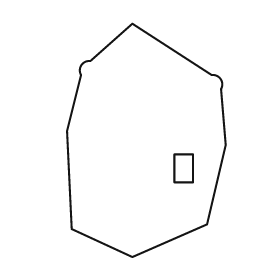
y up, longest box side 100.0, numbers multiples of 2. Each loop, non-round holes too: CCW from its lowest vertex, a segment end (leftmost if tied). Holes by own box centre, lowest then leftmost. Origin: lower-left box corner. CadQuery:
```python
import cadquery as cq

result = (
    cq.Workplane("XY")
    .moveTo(28.0, 0.0)
    .lineTo(60.0, 14.0)
    .lineTo(68.0, 48.0)
    .lineTo(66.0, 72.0)
    .threePointArc((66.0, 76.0), (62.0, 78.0))
    .lineTo(28.0, 100.0)
    .lineTo(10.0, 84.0)
    .threePointArc((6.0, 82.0), (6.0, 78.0))
    .lineTo(0.0, 54.0)
    .lineTo(2.0, 12.0)
    .close()
    .moveTo(46.0, 32.0)
    .lineTo(54.0, 32.0)
    .lineTo(54.0, 44.0)
    .lineTo(46.0, 44.0)
    .close()
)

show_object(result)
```